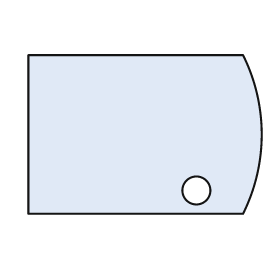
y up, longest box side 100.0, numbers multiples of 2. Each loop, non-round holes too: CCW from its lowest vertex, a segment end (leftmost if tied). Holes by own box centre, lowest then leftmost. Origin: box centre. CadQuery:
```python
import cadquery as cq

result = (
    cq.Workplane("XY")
    .moveTo(-50.0, -34.0)
    .lineTo(42.0, -34.0)
    .threePointArc((50.0, 0.0), (42.0, 34.0))
    .lineTo(-50.0, 34.0)
    .close()
    .moveTo(22.0, -24.0)
    .circle(6.0)
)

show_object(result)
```